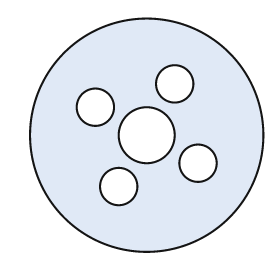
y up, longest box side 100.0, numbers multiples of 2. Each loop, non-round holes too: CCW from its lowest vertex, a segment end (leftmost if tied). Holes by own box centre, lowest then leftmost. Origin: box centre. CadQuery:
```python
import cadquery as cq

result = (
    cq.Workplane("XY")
    .moveTo(0.0, 0.0)
    .circle(50.0)
    .moveTo(-12.0, -22.0)
    .circle(8.0)
    .moveTo(22.0, -12.0)
    .circle(8.0)
    .moveTo(0.0, 0.0)
    .circle(12.0)
    .moveTo(-22.0, 12.0)
    .circle(8.0)
    .moveTo(12.0, 22.0)
    .circle(8.0)
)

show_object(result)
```